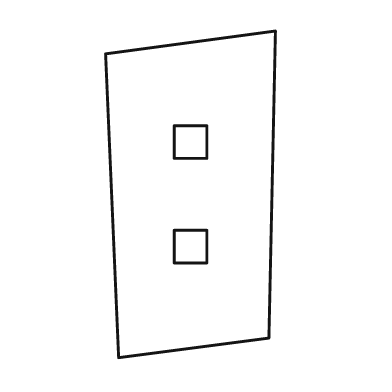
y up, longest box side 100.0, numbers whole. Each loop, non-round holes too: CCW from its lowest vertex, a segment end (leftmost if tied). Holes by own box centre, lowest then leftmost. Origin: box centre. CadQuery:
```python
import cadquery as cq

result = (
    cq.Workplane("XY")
    .moveTo(-22.0, -50.0)
    .lineTo(24.0, -44.0)
    .lineTo(26.0, 50.0)
    .lineTo(-26.0, 43.0)
    .close()
    .moveTo(-5.0, -21.0)
    .lineTo(5.0, -21.0)
    .lineTo(5.0, -11.0)
    .lineTo(-5.0, -11.0)
    .close()
    .moveTo(-5.0, 11.0)
    .lineTo(5.0, 11.0)
    .lineTo(5.0, 21.0)
    .lineTo(-5.0, 21.0)
    .close()
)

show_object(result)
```